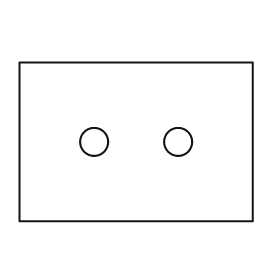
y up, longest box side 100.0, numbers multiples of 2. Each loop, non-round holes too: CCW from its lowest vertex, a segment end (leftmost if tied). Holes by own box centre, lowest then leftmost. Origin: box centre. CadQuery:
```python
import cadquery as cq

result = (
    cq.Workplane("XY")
    .moveTo(-50.0, -34.0)
    .lineTo(50.0, -34.0)
    .lineTo(50.0, 34.0)
    .lineTo(-50.0, 34.0)
    .close()
    .moveTo(-18.0, 0.0)
    .circle(6.0)
    .moveTo(18.0, 0.0)
    .circle(6.0)
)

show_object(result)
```